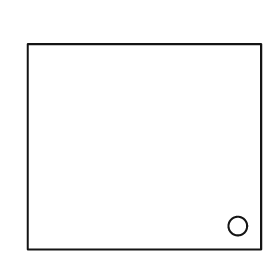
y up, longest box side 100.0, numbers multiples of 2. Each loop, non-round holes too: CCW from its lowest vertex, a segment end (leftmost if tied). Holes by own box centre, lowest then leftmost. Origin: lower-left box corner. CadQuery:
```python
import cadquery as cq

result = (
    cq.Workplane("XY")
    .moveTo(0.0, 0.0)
    .lineTo(100.0, 0.0)
    .lineTo(100.0, 88.0)
    .lineTo(0.0, 88.0)
    .close()
    .moveTo(90.0, 10.0)
    .circle(4.0)
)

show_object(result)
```